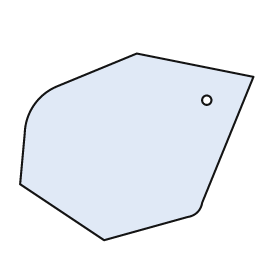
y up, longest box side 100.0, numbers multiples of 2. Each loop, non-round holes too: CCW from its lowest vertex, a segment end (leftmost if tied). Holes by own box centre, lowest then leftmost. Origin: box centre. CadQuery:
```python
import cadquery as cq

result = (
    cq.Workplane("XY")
    .moveTo(-14.0, -40.0)
    .lineTo(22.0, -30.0)
    .threePointArc((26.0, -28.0), (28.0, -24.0))
    .lineTo(50.0, 30.0)
    .lineTo(0.0, 40.0)
    .lineTo(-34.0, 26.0)
    .threePointArc((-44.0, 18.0), (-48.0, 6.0))
    .lineTo(-50.0, -16.0)
    .close()
    .moveTo(30.0, 20.0)
    .circle(2.0)
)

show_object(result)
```